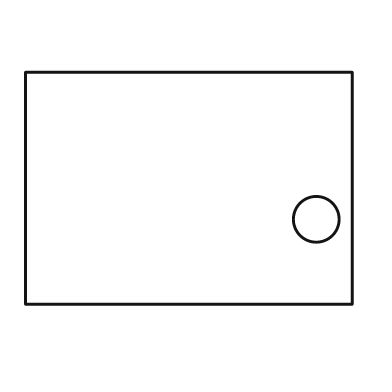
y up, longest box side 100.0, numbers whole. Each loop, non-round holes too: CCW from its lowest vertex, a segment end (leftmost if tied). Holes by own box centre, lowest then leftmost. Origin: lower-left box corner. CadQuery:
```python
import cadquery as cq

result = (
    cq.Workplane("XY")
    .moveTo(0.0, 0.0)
    .lineTo(100.0, 0.0)
    .lineTo(100.0, 71.0)
    .lineTo(0.0, 71.0)
    .close()
    .moveTo(89.0, 26.0)
    .circle(7.0)
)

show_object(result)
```